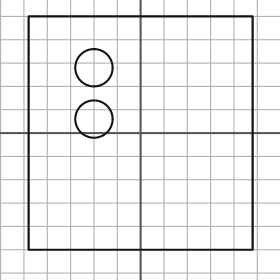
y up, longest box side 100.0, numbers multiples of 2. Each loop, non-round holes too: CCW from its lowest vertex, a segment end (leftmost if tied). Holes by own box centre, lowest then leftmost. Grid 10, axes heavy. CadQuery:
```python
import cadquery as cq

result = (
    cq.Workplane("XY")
    .moveTo(-48.0, -50.0)
    .lineTo(48.0, -50.0)
    .lineTo(48.0, 50.0)
    .lineTo(-48.0, 50.0)
    .close()
    .moveTo(-20.0, 6.0)
    .circle(8.0)
    .moveTo(-20.0, 28.0)
    .circle(8.0)
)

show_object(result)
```